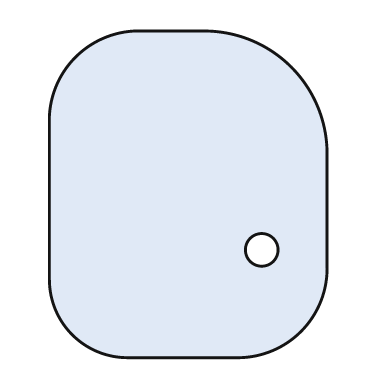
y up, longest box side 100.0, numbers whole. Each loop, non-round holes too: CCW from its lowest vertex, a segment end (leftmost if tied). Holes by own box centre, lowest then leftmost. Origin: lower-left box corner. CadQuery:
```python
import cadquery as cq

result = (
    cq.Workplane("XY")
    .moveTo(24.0, 0.0)
    .lineTo(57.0, 0.0)
    .threePointArc((77.0, 8.0), (85.0, 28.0))
    .lineTo(85.0, 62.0)
    .threePointArc((74.0, 89.0), (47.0, 100.0))
    .lineTo(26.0, 100.0)
    .threePointArc((8.0, 92.0), (0.0, 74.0))
    .lineTo(0.0, 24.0)
    .threePointArc((7.0, 7.0), (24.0, 0.0))
    .close()
    .moveTo(65.0, 33.0)
    .circle(5.0)
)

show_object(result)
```